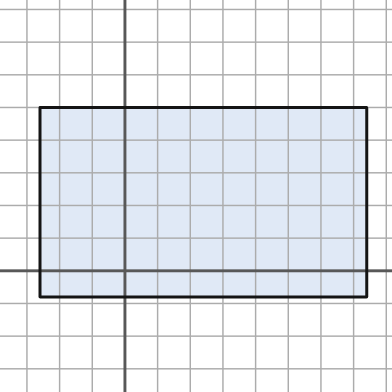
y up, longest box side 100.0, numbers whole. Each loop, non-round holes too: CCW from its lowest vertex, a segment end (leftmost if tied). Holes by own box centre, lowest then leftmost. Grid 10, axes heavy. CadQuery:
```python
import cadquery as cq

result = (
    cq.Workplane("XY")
    .moveTo(-26.0, -8.0)
    .lineTo(74.0, -8.0)
    .lineTo(74.0, 50.0)
    .lineTo(-26.0, 50.0)
    .close()
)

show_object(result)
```